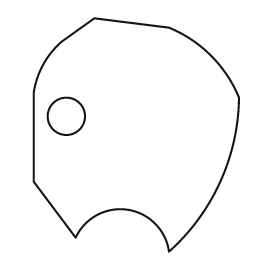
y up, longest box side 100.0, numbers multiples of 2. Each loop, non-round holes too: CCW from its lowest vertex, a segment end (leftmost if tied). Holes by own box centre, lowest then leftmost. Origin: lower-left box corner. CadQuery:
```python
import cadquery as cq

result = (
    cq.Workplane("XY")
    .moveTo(58.0, 0.0)
    .threePointArc((80.0, 30.0), (88.0, 66.0))
    .threePointArc((76.0, 84.0), (58.0, 96.0))
    .lineTo(26.0, 100.0)
    .lineTo(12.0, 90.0)
    .threePointArc((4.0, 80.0), (0.0, 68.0))
    .lineTo(0.0, 30.0)
    .lineTo(18.0, 6.0)
    .threePointArc((40.0, 18.0), (58.0, 0.0))
    .close()
    .moveTo(14.0, 58.0)
    .circle(8.0)
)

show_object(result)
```